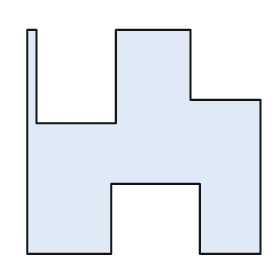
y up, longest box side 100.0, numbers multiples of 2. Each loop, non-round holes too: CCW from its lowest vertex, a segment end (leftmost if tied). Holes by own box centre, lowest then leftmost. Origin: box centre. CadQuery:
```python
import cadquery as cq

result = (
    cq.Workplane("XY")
    .moveTo(-50.0, -48.0)
    .lineTo(-14.0, -48.0)
    .lineTo(-14.0, -18.0)
    .lineTo(24.0, -18.0)
    .lineTo(24.0, -48.0)
    .lineTo(50.0, -48.0)
    .lineTo(50.0, 18.0)
    .lineTo(20.0, 18.0)
    .lineTo(20.0, 48.0)
    .lineTo(-12.0, 48.0)
    .lineTo(-12.0, 8.0)
    .lineTo(-46.0, 8.0)
    .lineTo(-46.0, 48.0)
    .lineTo(-50.0, 48.0)
    .close()
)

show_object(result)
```